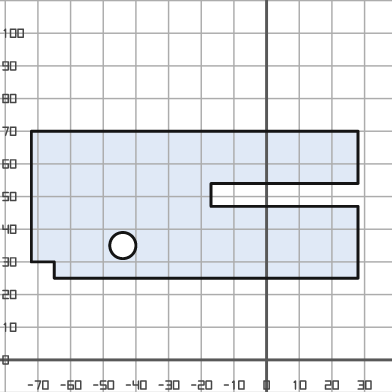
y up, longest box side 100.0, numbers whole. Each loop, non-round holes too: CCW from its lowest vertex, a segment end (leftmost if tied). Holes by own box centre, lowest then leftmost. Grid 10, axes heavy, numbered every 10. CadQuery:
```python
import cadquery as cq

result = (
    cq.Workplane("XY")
    .moveTo(-65.0, 25.0)
    .lineTo(28.0, 25.0)
    .lineTo(28.0, 47.0)
    .lineTo(-17.0, 47.0)
    .lineTo(-17.0, 54.0)
    .lineTo(28.0, 54.0)
    .lineTo(28.0, 70.0)
    .lineTo(-72.0, 70.0)
    .lineTo(-72.0, 30.0)
    .lineTo(-65.0, 30.0)
    .close()
    .moveTo(-44.0, 35.0)
    .circle(4.0)
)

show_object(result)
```